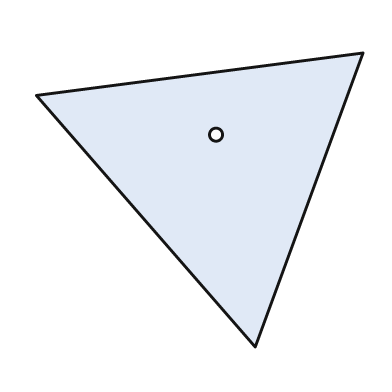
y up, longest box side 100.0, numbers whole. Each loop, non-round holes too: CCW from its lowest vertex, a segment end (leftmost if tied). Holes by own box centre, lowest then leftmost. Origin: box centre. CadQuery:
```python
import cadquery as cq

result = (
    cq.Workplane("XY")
    .moveTo(17.0, -45.0)
    .lineTo(50.0, 45.0)
    .lineTo(-50.0, 32.0)
    .close()
    .moveTo(5.0, 20.0)
    .circle(2.0)
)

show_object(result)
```